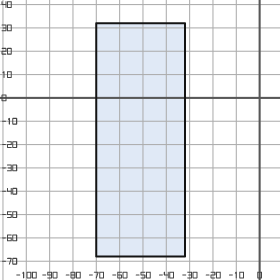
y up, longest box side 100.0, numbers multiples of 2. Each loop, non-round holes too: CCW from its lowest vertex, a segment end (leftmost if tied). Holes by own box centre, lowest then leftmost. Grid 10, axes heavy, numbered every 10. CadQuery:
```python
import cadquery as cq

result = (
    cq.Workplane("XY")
    .moveTo(-70.0, -68.0)
    .lineTo(-32.0, -68.0)
    .lineTo(-32.0, 32.0)
    .lineTo(-70.0, 32.0)
    .close()
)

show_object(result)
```